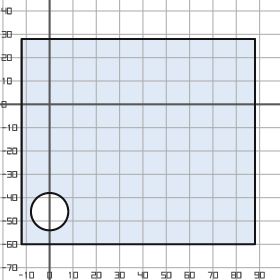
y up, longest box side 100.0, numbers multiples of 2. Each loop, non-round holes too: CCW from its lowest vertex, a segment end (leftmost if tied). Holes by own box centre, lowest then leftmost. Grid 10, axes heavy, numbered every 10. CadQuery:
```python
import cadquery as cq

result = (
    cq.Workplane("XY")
    .moveTo(-12.0, -60.0)
    .lineTo(88.0, -60.0)
    .lineTo(88.0, 28.0)
    .lineTo(-12.0, 28.0)
    .close()
    .moveTo(0.0, -46.0)
    .circle(8.0)
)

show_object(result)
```